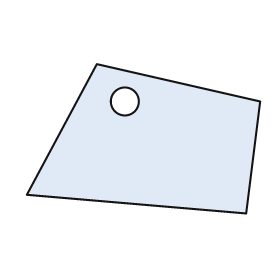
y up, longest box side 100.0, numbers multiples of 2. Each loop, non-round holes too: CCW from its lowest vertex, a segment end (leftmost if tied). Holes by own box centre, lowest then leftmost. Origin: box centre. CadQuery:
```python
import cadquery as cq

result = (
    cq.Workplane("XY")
    .moveTo(44.0, -32.0)
    .lineTo(50.0, 16.0)
    .lineTo(-20.0, 32.0)
    .lineTo(-50.0, -24.0)
    .close()
    .moveTo(-8.0, 16.0)
    .circle(6.0)
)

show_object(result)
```